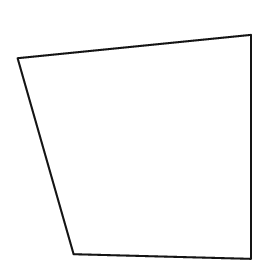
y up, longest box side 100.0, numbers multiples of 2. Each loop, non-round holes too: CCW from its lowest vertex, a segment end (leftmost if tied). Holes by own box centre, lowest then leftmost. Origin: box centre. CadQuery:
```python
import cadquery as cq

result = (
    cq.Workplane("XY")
    .moveTo(50.0, -48.0)
    .lineTo(50.0, 48.0)
    .lineTo(-50.0, 38.0)
    .lineTo(-26.0, -46.0)
    .close()
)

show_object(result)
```